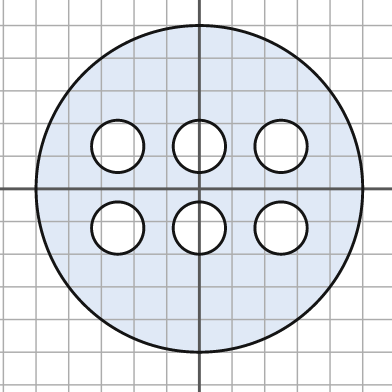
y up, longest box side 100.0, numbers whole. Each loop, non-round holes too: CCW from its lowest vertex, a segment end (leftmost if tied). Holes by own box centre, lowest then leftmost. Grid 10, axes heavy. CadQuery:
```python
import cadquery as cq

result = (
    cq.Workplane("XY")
    .moveTo(0.0, 0.0)
    .circle(50.0)
    .moveTo(-25.0, -12.0)
    .circle(8.0)
    .moveTo(0.0, -12.0)
    .circle(8.0)
    .moveTo(25.0, -12.0)
    .circle(8.0)
    .moveTo(-25.0, 13.0)
    .circle(8.0)
    .moveTo(0.0, 13.0)
    .circle(8.0)
    .moveTo(25.0, 13.0)
    .circle(8.0)
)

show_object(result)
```